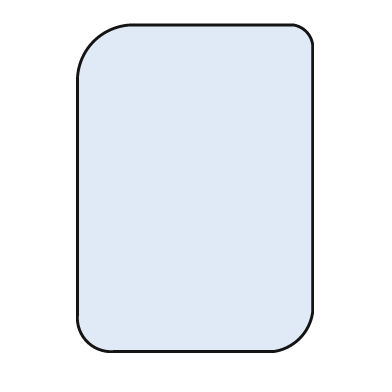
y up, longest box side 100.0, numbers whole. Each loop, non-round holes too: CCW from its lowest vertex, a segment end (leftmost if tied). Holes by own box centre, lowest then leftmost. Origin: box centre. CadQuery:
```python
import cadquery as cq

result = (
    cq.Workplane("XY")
    .moveTo(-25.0, -50.0)
    .lineTo(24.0, -50.0)
    .threePointArc((32.0, -46.0), (36.0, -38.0))
    .lineTo(36.0, 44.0)
    .threePointArc((34.0, 48.0), (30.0, 50.0))
    .lineTo(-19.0, 50.0)
    .threePointArc((-31.0, 45.0), (-36.0, 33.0))
    .lineTo(-36.0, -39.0)
    .threePointArc((-33.0, -47.0), (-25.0, -50.0))
    .close()
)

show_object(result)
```